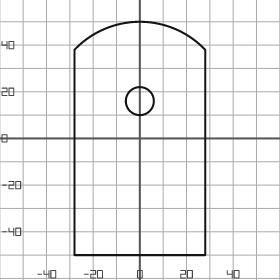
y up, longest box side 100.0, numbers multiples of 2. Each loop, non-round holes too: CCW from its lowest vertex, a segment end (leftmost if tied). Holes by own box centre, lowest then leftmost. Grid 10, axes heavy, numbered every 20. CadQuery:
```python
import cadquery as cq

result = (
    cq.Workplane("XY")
    .moveTo(-28.0, -50.0)
    .lineTo(28.0, -50.0)
    .lineTo(28.0, 38.0)
    .threePointArc((0.0, 50.0), (-28.0, 38.0))
    .close()
    .moveTo(0.0, 16.0)
    .circle(6.0)
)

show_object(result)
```